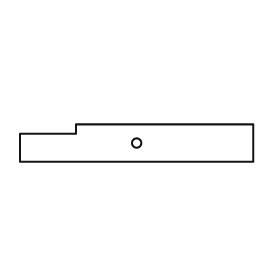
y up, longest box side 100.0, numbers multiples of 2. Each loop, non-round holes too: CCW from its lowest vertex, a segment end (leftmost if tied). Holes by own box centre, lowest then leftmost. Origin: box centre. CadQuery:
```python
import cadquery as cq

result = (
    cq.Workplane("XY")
    .moveTo(-50.0, -8.0)
    .lineTo(50.0, -8.0)
    .lineTo(50.0, 8.0)
    .lineTo(-26.0, 8.0)
    .lineTo(-26.0, 4.0)
    .lineTo(-50.0, 4.0)
    .close()
    .moveTo(0.0, 0.0)
    .circle(2.0)
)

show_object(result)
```